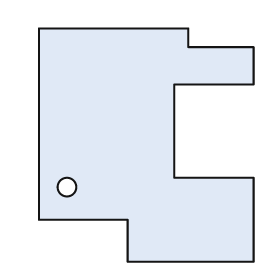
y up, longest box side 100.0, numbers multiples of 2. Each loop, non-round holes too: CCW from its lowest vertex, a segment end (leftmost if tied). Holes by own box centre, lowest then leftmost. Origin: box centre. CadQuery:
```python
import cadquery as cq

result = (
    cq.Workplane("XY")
    .moveTo(-8.0, -50.0)
    .lineTo(46.0, -50.0)
    .lineTo(46.0, -14.0)
    .lineTo(12.0, -14.0)
    .lineTo(12.0, 26.0)
    .lineTo(46.0, 26.0)
    .lineTo(46.0, 42.0)
    .lineTo(18.0, 42.0)
    .lineTo(18.0, 50.0)
    .lineTo(-46.0, 50.0)
    .lineTo(-46.0, -32.0)
    .lineTo(-8.0, -32.0)
    .close()
    .moveTo(-34.0, -18.0)
    .circle(4.0)
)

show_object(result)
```